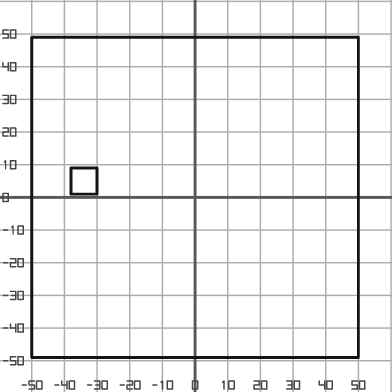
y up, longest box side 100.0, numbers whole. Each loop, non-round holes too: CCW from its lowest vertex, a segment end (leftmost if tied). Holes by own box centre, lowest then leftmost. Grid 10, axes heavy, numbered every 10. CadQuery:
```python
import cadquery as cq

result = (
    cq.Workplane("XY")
    .moveTo(-50.0, -49.0)
    .lineTo(50.0, -49.0)
    .lineTo(50.0, 49.0)
    .lineTo(-50.0, 49.0)
    .close()
    .moveTo(-38.0, 1.0)
    .lineTo(-30.0, 1.0)
    .lineTo(-30.0, 9.0)
    .lineTo(-38.0, 9.0)
    .close()
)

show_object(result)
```